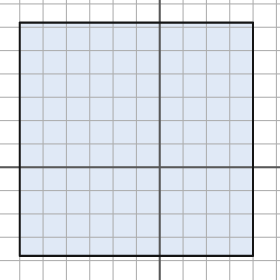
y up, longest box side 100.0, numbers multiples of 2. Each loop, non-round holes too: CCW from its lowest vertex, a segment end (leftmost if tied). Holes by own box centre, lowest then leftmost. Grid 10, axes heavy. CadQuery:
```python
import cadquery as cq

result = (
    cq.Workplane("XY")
    .moveTo(-60.0, -38.0)
    .lineTo(40.0, -38.0)
    .lineTo(40.0, 62.0)
    .lineTo(-60.0, 62.0)
    .close()
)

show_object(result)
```